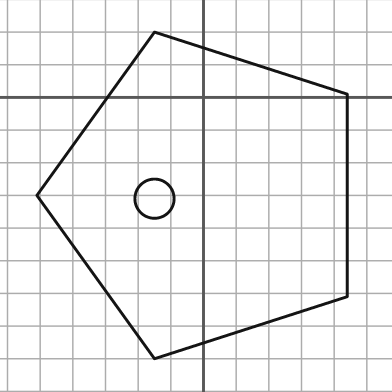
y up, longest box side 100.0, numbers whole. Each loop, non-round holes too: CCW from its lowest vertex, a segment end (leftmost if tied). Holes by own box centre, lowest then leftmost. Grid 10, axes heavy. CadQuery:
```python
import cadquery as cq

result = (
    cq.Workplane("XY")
    .moveTo(-15.0, -80.0)
    .lineTo(44.0, -61.0)
    .lineTo(44.0, 1.0)
    .lineTo(-15.0, 20.0)
    .lineTo(-51.0, -30.0)
    .close()
    .moveTo(-15.0, -31.0)
    .circle(6.0)
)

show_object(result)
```